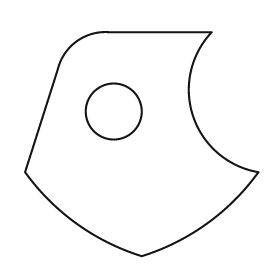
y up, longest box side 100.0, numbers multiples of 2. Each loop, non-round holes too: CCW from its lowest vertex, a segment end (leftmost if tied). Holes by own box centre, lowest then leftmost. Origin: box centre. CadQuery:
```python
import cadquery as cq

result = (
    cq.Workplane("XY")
    .moveTo(0.0, -48.0)
    .threePointArc((28.0, -34.0), (50.0, -12.0))
    .threePointArc((22.0, 12.0), (30.0, 48.0))
    .lineTo(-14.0, 48.0)
    .threePointArc((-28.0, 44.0), (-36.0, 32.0))
    .lineTo(-50.0, -12.0)
    .threePointArc((-28.0, -34.0), (0.0, -48.0))
    .close()
    .moveTo(-12.0, 14.0)
    .circle(12.0)
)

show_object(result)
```